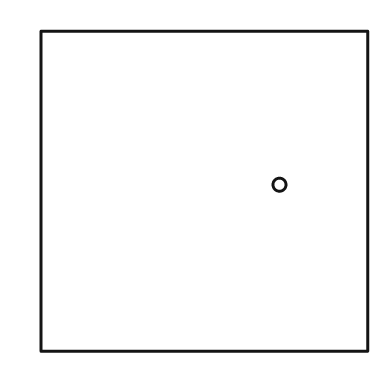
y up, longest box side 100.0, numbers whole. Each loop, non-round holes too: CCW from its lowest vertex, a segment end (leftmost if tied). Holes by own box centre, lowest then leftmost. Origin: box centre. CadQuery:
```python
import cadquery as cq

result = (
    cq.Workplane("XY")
    .moveTo(-50.0, -49.0)
    .lineTo(50.0, -49.0)
    .lineTo(50.0, 49.0)
    .lineTo(-50.0, 49.0)
    .close()
    .moveTo(23.0, 2.0)
    .circle(2.0)
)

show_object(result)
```